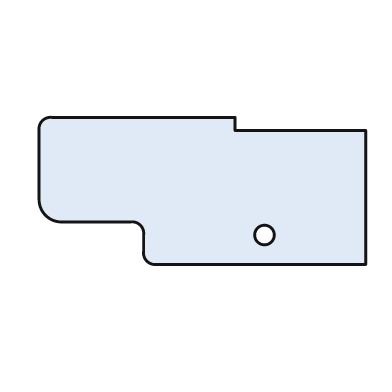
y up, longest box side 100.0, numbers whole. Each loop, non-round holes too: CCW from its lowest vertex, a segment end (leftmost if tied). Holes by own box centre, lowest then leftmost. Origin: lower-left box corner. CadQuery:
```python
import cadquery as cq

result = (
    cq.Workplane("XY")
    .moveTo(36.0, 0.0)
    .lineTo(100.0, 0.0)
    .lineTo(100.0, 41.0)
    .lineTo(60.0, 41.0)
    .lineTo(60.0, 45.0)
    .lineTo(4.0, 45.0)
    .threePointArc((1.0, 44.0), (0.0, 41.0))
    .lineTo(0.0, 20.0)
    .threePointArc((2.0, 15.0), (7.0, 13.0))
    .lineTo(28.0, 13.0)
    .threePointArc((31.0, 12.0), (32.0, 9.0))
    .lineTo(32.0, 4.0)
    .threePointArc((33.0, 1.0), (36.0, 0.0))
    .close()
    .moveTo(69.0, 9.0)
    .circle(3.0)
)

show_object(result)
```